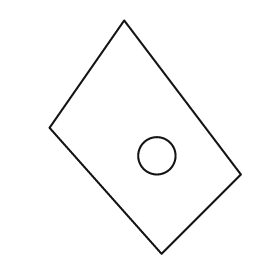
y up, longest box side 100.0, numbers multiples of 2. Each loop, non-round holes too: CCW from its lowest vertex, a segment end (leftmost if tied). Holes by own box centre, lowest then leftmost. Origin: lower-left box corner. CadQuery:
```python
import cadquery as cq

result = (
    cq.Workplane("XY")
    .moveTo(48.0, 0.0)
    .lineTo(82.0, 34.0)
    .lineTo(32.0, 100.0)
    .lineTo(0.0, 54.0)
    .close()
    .moveTo(46.0, 42.0)
    .circle(8.0)
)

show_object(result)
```